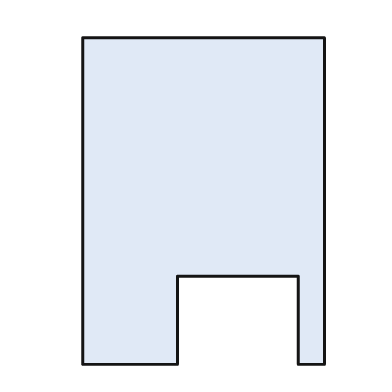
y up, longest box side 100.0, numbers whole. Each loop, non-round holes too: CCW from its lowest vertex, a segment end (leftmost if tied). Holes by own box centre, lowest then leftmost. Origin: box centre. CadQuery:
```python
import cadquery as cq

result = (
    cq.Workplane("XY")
    .moveTo(-37.0, -50.0)
    .lineTo(-8.0, -50.0)
    .lineTo(-8.0, -23.0)
    .lineTo(29.0, -23.0)
    .lineTo(29.0, -50.0)
    .lineTo(37.0, -50.0)
    .lineTo(37.0, 50.0)
    .lineTo(-37.0, 50.0)
    .close()
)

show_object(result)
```